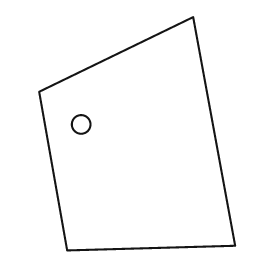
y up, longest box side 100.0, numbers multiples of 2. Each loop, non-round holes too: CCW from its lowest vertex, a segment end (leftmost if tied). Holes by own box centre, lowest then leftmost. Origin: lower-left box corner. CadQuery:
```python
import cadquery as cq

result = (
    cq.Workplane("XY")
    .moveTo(12.0, 0.0)
    .lineTo(84.0, 2.0)
    .lineTo(66.0, 100.0)
    .lineTo(0.0, 68.0)
    .close()
    .moveTo(18.0, 54.0)
    .circle(4.0)
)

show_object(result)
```